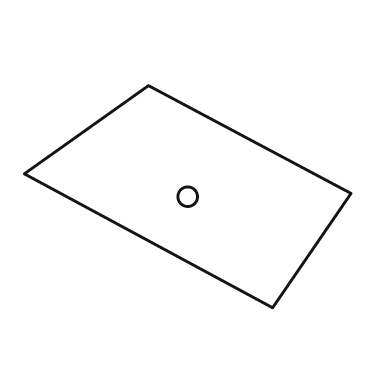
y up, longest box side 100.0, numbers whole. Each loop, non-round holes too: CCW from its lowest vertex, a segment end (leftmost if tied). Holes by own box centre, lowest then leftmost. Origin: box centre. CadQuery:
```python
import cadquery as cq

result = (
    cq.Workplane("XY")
    .moveTo(26.0, -34.0)
    .lineTo(50.0, 1.0)
    .lineTo(-12.0, 34.0)
    .lineTo(-50.0, 7.0)
    .close()
    .moveTo(0.0, 0.0)
    .circle(3.0)
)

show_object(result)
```